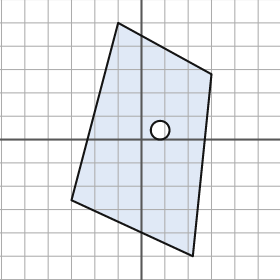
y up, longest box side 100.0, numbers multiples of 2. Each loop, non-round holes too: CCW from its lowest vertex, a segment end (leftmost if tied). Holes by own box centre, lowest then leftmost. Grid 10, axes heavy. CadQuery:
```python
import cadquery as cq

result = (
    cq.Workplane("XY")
    .moveTo(22.0, -50.0)
    .lineTo(30.0, 28.0)
    .lineTo(-10.0, 50.0)
    .lineTo(-30.0, -26.0)
    .close()
    .moveTo(8.0, 4.0)
    .circle(4.0)
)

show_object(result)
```